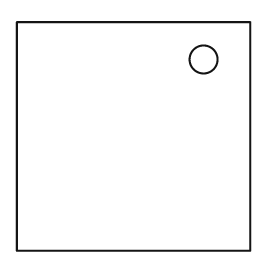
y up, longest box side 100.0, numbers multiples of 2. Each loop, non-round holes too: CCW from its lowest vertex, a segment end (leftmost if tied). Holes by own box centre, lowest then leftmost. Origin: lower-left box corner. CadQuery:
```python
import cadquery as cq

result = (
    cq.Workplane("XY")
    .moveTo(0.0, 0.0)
    .lineTo(100.0, 0.0)
    .lineTo(100.0, 98.0)
    .lineTo(0.0, 98.0)
    .close()
    .moveTo(80.0, 82.0)
    .circle(6.0)
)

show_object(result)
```